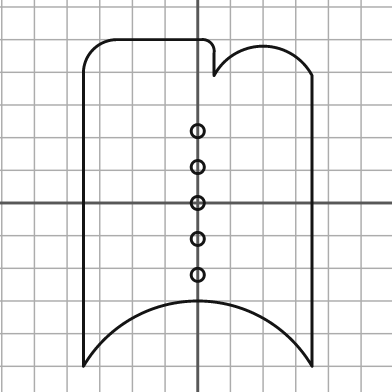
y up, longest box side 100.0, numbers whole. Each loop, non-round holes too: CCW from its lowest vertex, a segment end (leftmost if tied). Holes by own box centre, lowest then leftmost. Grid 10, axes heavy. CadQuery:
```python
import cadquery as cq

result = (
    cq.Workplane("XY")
    .moveTo(-35.0, -50.0)
    .threePointArc((0.0, -30.0), (35.0, -50.0))
    .lineTo(35.0, 39.0)
    .threePointArc((20.0, 48.0), (5.0, 39.0))
    .lineTo(5.0, 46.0)
    .threePointArc((4.0, 49.0), (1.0, 50.0))
    .lineTo(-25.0, 50.0)
    .threePointArc((-32.0, 47.0), (-35.0, 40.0))
    .close()
    .moveTo(0.0, -22.0)
    .circle(2.0)
    .moveTo(0.0, -11.0)
    .circle(2.0)
    .moveTo(0.0, 0.0)
    .circle(2.0)
    .moveTo(0.0, 11.0)
    .circle(2.0)
    .moveTo(0.0, 22.0)
    .circle(2.0)
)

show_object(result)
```